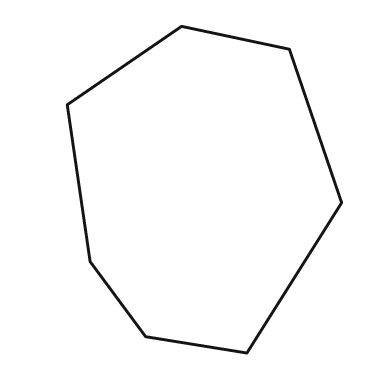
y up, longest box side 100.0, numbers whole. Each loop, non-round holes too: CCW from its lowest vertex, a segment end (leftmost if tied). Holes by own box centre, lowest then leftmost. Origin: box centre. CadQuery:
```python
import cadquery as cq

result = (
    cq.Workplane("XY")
    .moveTo(13.0, -50.0)
    .lineTo(42.0, -4.0)
    .lineTo(26.0, 43.0)
    .lineTo(-7.0, 50.0)
    .lineTo(-42.0, 26.0)
    .lineTo(-35.0, -22.0)
    .lineTo(-18.0, -45.0)
    .close()
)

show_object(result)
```